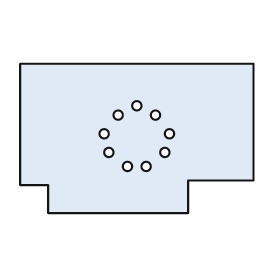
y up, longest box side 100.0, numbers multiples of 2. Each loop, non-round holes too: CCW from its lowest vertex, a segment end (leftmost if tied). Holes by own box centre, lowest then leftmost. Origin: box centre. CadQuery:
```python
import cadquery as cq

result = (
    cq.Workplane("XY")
    .moveTo(-38.0, -32.0)
    .lineTo(22.0, -32.0)
    .lineTo(22.0, -18.0)
    .lineTo(50.0, -18.0)
    .lineTo(50.0, 32.0)
    .lineTo(-50.0, 32.0)
    .lineTo(-50.0, -20.0)
    .lineTo(-38.0, -20.0)
    .close()
    .moveTo(-4.0, -12.0)
    .circle(2.0)
    .moveTo(4.0, -12.0)
    .circle(2.0)
    .moveTo(-12.0, -6.0)
    .circle(2.0)
    .moveTo(12.0, -6.0)
    .circle(2.0)
    .moveTo(-14.0, 2.0)
    .circle(2.0)
    .moveTo(14.0, 2.0)
    .circle(2.0)
    .moveTo(-8.0, 10.0)
    .circle(2.0)
    .moveTo(8.0, 10.0)
    .circle(2.0)
    .moveTo(0.0, 14.0)
    .circle(2.0)
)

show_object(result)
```